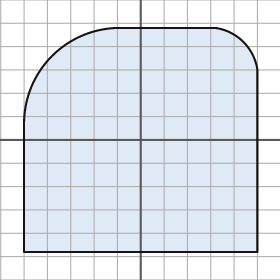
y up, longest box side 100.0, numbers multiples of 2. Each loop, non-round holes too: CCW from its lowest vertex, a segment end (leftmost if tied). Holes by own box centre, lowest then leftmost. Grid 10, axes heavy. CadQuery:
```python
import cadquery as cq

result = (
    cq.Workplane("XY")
    .moveTo(-50.0, -48.0)
    .lineTo(50.0, -48.0)
    .lineTo(50.0, 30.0)
    .threePointArc((44.0, 42.0), (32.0, 48.0))
    .lineTo(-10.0, 48.0)
    .threePointArc((-38.0, 36.0), (-50.0, 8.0))
    .close()
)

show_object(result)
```